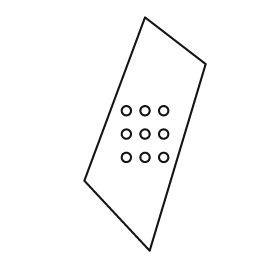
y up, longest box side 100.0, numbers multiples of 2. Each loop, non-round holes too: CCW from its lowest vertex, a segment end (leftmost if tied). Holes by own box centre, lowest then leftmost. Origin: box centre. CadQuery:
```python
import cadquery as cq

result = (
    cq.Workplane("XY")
    .moveTo(2.0, -50.0)
    .lineTo(26.0, 30.0)
    .lineTo(0.0, 50.0)
    .lineTo(-26.0, -20.0)
    .close()
    .moveTo(-8.0, -10.0)
    .circle(2.0)
    .moveTo(0.0, -10.0)
    .circle(2.0)
    .moveTo(8.0, -10.0)
    .circle(2.0)
    .moveTo(-8.0, 0.0)
    .circle(2.0)
    .moveTo(0.0, 0.0)
    .circle(2.0)
    .moveTo(8.0, 0.0)
    .circle(2.0)
    .moveTo(-8.0, 10.0)
    .circle(2.0)
    .moveTo(0.0, 10.0)
    .circle(2.0)
    .moveTo(8.0, 10.0)
    .circle(2.0)
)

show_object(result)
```